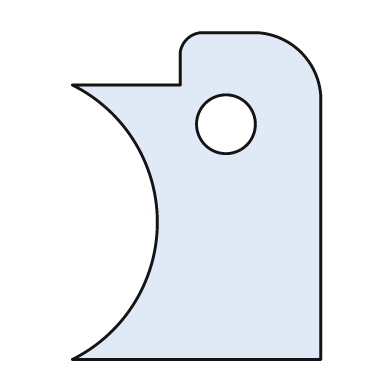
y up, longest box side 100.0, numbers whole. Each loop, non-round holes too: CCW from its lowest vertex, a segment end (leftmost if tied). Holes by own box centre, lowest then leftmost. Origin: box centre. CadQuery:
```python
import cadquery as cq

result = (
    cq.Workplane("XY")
    .moveTo(-38.0, -50.0)
    .lineTo(38.0, -50.0)
    .lineTo(38.0, 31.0)
    .threePointArc((32.0, 44.0), (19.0, 50.0))
    .lineTo(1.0, 50.0)
    .threePointArc((-3.0, 48.0), (-5.0, 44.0))
    .lineTo(-5.0, 34.0)
    .lineTo(-38.0, 34.0)
    .threePointArc((-12.0, -8.0), (-38.0, -50.0))
    .close()
    .moveTo(9.0, 22.0)
    .circle(9.0)
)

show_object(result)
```